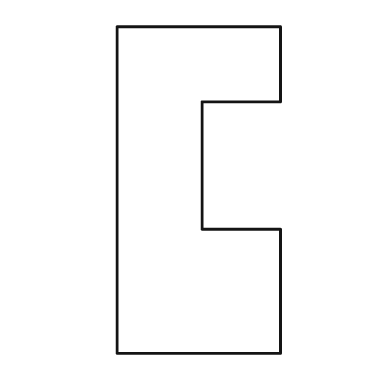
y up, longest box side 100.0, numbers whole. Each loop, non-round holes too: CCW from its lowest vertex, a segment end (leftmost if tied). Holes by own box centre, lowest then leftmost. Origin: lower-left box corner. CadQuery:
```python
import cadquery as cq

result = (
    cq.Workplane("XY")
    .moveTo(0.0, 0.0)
    .lineTo(50.0, 0.0)
    .lineTo(50.0, 38.0)
    .lineTo(26.0, 38.0)
    .lineTo(26.0, 77.0)
    .lineTo(50.0, 77.0)
    .lineTo(50.0, 100.0)
    .lineTo(0.0, 100.0)
    .close()
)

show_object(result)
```